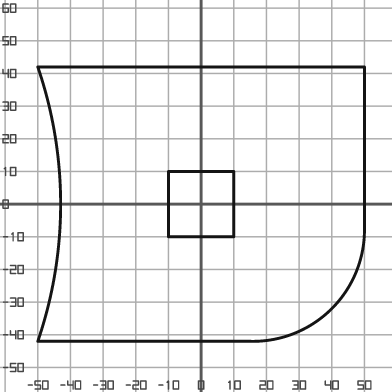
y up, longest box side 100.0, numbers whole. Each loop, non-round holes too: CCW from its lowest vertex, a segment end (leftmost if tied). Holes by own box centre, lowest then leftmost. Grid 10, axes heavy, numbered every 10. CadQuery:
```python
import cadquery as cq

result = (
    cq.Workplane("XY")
    .moveTo(-50.0, -42.0)
    .lineTo(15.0, -42.0)
    .threePointArc((40.0, -32.0), (50.0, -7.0))
    .lineTo(50.0, 42.0)
    .lineTo(-50.0, 42.0)
    .threePointArc((-43.0, 0.0), (-50.0, -42.0))
    .close()
    .moveTo(-10.0, -10.0)
    .lineTo(10.0, -10.0)
    .lineTo(10.0, 10.0)
    .lineTo(-10.0, 10.0)
    .close()
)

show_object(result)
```